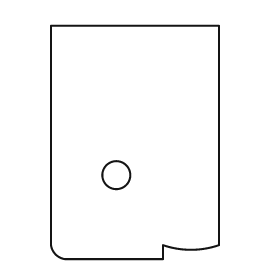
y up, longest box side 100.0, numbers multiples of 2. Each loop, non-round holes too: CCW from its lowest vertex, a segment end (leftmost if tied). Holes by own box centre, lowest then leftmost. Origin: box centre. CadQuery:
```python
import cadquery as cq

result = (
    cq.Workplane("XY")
    .moveTo(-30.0, -50.0)
    .lineTo(12.0, -50.0)
    .lineTo(12.0, -44.0)
    .threePointArc((24.0, -46.0), (36.0, -44.0))
    .lineTo(36.0, 50.0)
    .lineTo(-36.0, 50.0)
    .lineTo(-36.0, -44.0)
    .threePointArc((-34.0, -48.0), (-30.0, -50.0))
    .close()
    .moveTo(-8.0, -14.0)
    .circle(6.0)
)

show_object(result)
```